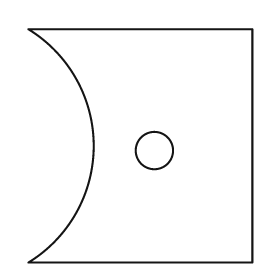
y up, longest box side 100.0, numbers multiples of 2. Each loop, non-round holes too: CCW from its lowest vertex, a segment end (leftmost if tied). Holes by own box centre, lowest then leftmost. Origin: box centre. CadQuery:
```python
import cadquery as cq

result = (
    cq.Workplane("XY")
    .moveTo(-48.0, -50.0)
    .lineTo(48.0, -50.0)
    .lineTo(48.0, 50.0)
    .lineTo(-48.0, 50.0)
    .threePointArc((-20.0, 0.0), (-48.0, -50.0))
    .close()
    .moveTo(6.0, -2.0)
    .circle(8.0)
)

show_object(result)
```